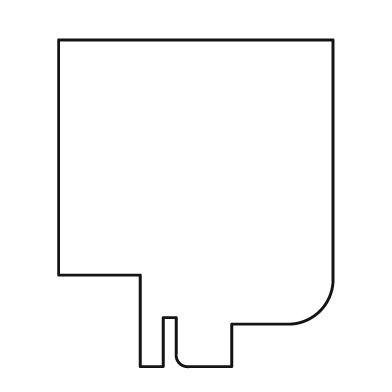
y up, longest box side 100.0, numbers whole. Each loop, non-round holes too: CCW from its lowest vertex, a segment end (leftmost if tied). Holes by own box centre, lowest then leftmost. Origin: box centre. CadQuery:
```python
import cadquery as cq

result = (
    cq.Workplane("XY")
    .moveTo(-17.0, -50.0)
    .lineTo(-10.0, -50.0)
    .lineTo(-10.0, -35.0)
    .lineTo(-6.0, -35.0)
    .lineTo(-6.0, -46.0)
    .threePointArc((-5.0, -49.0), (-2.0, -50.0))
    .lineTo(11.0, -50.0)
    .lineTo(11.0, -37.0)
    .lineTo(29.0, -37.0)
    .threePointArc((38.0, -33.0), (42.0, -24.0))
    .lineTo(42.0, 50.0)
    .lineTo(-42.0, 50.0)
    .lineTo(-42.0, -22.0)
    .lineTo(-17.0, -22.0)
    .close()
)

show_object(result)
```